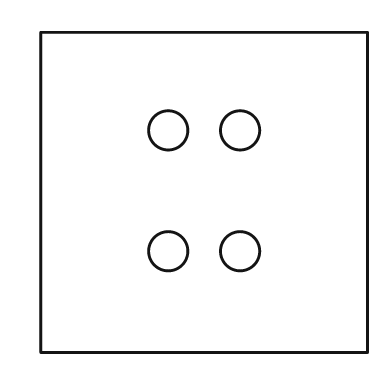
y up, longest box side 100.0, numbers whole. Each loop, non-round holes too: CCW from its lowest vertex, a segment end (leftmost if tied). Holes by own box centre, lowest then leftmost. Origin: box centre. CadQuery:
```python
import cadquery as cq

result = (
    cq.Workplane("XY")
    .moveTo(-50.0, -49.0)
    .lineTo(50.0, -49.0)
    .lineTo(50.0, 49.0)
    .lineTo(-50.0, 49.0)
    .close()
    .moveTo(-11.0, -18.0)
    .circle(6.0)
    .moveTo(11.0, -18.0)
    .circle(6.0)
    .moveTo(-11.0, 19.0)
    .circle(6.0)
    .moveTo(11.0, 19.0)
    .circle(6.0)
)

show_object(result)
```